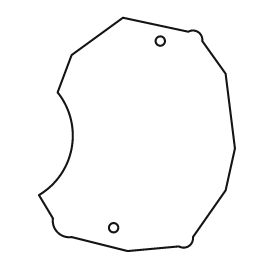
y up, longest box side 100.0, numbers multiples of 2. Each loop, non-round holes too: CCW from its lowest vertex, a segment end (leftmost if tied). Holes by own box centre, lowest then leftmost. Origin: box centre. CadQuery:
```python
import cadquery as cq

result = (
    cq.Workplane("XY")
    .moveTo(-4.0, -50.0)
    .lineTo(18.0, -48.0)
    .threePointArc((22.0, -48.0), (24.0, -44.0))
    .lineTo(38.0, -24.0)
    .lineTo(42.0, -6.0)
    .lineTo(38.0, 26.0)
    .lineTo(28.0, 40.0)
    .threePointArc((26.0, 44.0), (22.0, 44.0))
    .lineTo(-6.0, 50.0)
    .lineTo(-28.0, 34.0)
    .lineTo(-34.0, 18.0)
    .threePointArc((-28.0, -6.0), (-42.0, -26.0))
    .lineTo(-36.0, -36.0)
    .threePointArc((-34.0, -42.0), (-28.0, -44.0))
    .close()
    .moveTo(-10.0, -40.0)
    .circle(2.0)
    .moveTo(10.0, 40.0)
    .circle(2.0)
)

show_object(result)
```